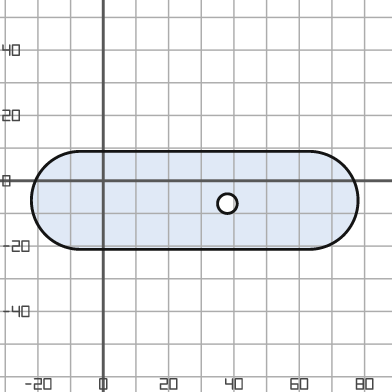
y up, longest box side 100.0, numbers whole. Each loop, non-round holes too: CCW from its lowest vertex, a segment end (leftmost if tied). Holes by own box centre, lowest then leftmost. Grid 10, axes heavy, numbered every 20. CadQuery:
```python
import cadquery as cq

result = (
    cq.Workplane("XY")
    .moveTo(-7.0, -21.0)
    .lineTo(63.0, -21.0)
    .threePointArc((78.0, -6.0), (63.0, 9.0))
    .lineTo(-7.0, 9.0)
    .threePointArc((-22.0, -6.0), (-7.0, -21.0))
    .close()
    .moveTo(38.0, -7.0)
    .circle(3.0)
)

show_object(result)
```